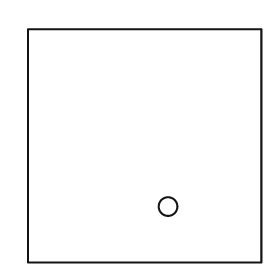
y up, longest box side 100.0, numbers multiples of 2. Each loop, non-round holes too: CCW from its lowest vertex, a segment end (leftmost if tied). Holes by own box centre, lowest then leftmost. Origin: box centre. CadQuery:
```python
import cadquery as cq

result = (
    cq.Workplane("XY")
    .moveTo(-50.0, -50.0)
    .lineTo(50.0, -50.0)
    .lineTo(50.0, 50.0)
    .lineTo(-50.0, 50.0)
    .close()
    .moveTo(10.0, -26.0)
    .circle(4.0)
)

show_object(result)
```